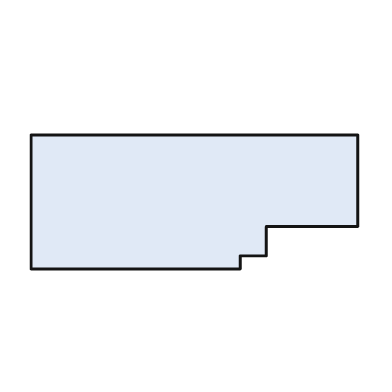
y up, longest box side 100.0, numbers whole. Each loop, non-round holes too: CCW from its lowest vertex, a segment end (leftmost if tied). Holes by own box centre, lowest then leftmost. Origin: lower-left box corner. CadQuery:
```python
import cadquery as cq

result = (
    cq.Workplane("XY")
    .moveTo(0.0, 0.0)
    .lineTo(64.0, 0.0)
    .lineTo(64.0, 4.0)
    .lineTo(72.0, 4.0)
    .lineTo(72.0, 13.0)
    .lineTo(100.0, 13.0)
    .lineTo(100.0, 41.0)
    .lineTo(0.0, 41.0)
    .close()
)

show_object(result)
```